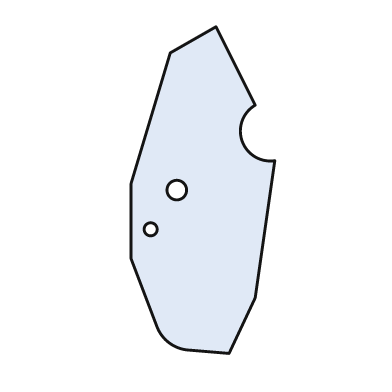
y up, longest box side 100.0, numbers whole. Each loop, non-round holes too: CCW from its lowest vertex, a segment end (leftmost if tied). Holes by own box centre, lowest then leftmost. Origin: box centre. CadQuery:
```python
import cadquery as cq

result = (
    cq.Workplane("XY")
    .moveTo(8.0, -50.0)
    .lineTo(16.0, -33.0)
    .lineTo(22.0, 9.0)
    .threePointArc((12.0, 15.0), (16.0, 26.0))
    .lineTo(4.0, 50.0)
    .lineTo(-10.0, 42.0)
    .lineTo(-22.0, 2.0)
    .lineTo(-22.0, -21.0)
    .lineTo(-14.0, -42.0)
    .threePointArc((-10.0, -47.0), (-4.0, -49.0))
    .close()
    .moveTo(-16.0, -12.0)
    .circle(2.0)
    .moveTo(-8.0, 0.0)
    .circle(3.0)
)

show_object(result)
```